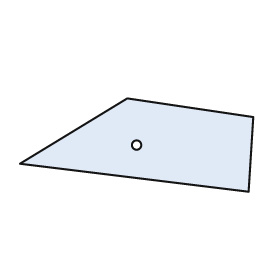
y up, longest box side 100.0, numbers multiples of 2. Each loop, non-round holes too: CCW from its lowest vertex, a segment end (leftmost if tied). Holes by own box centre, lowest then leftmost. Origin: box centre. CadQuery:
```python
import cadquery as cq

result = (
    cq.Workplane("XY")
    .moveTo(48.0, -20.0)
    .lineTo(50.0, 12.0)
    .lineTo(-4.0, 20.0)
    .lineTo(-50.0, -8.0)
    .close()
    .moveTo(0.0, 0.0)
    .circle(2.0)
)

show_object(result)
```